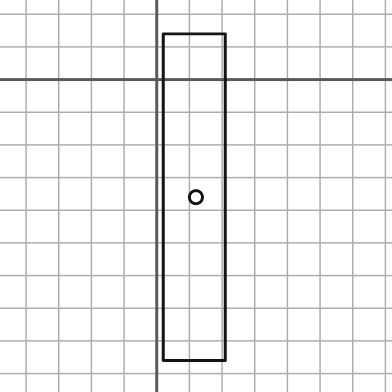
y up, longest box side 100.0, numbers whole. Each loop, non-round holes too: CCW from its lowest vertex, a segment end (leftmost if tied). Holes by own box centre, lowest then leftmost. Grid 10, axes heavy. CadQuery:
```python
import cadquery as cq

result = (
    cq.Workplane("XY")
    .moveTo(2.0, -86.0)
    .lineTo(21.0, -86.0)
    .lineTo(21.0, 14.0)
    .lineTo(2.0, 14.0)
    .close()
    .moveTo(12.0, -36.0)
    .circle(2.0)
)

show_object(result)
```